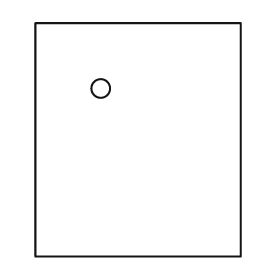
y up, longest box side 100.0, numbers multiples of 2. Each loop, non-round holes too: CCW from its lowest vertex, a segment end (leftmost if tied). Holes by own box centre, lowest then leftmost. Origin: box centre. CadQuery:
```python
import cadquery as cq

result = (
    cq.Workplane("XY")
    .moveTo(-44.0, -50.0)
    .lineTo(44.0, -50.0)
    .lineTo(44.0, 50.0)
    .lineTo(-44.0, 50.0)
    .close()
    .moveTo(-16.0, 22.0)
    .circle(4.0)
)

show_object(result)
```